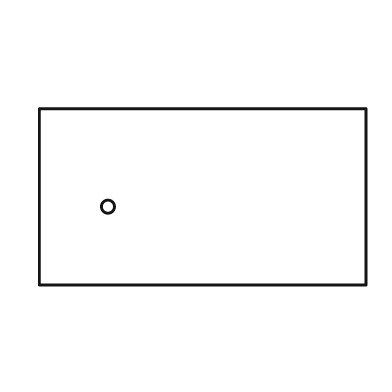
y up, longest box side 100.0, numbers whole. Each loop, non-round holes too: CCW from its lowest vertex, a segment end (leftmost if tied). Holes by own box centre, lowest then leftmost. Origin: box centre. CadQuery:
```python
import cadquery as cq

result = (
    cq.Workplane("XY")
    .moveTo(-50.0, -27.0)
    .lineTo(50.0, -27.0)
    .lineTo(50.0, 27.0)
    .lineTo(-50.0, 27.0)
    .close()
    .moveTo(-29.0, -3.0)
    .circle(2.0)
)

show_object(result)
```